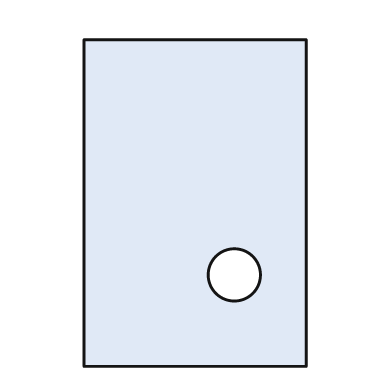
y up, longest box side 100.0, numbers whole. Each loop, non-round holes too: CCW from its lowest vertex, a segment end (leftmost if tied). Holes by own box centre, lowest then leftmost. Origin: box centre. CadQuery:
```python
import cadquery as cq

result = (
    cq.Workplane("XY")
    .moveTo(-34.0, -50.0)
    .lineTo(34.0, -50.0)
    .lineTo(34.0, 50.0)
    .lineTo(-34.0, 50.0)
    .close()
    .moveTo(12.0, -22.0)
    .circle(8.0)
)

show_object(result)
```